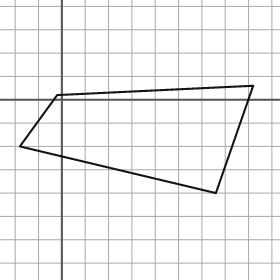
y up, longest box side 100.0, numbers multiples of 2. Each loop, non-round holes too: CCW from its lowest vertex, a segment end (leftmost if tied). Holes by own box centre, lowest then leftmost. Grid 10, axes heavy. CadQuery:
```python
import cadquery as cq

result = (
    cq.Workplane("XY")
    .moveTo(66.0, -40.0)
    .lineTo(82.0, 6.0)
    .lineTo(-2.0, 2.0)
    .lineTo(-18.0, -20.0)
    .close()
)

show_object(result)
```